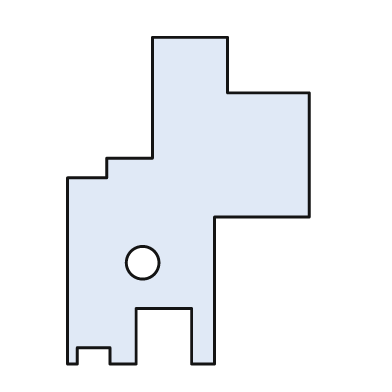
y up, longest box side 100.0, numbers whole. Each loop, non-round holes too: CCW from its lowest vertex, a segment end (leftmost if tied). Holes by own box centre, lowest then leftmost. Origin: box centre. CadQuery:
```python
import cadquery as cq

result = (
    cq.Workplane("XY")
    .moveTo(-37.0, -50.0)
    .lineTo(-34.0, -50.0)
    .lineTo(-34.0, -45.0)
    .lineTo(-24.0, -45.0)
    .lineTo(-24.0, -50.0)
    .lineTo(-16.0, -50.0)
    .lineTo(-16.0, -33.0)
    .lineTo(1.0, -33.0)
    .lineTo(1.0, -50.0)
    .lineTo(8.0, -50.0)
    .lineTo(8.0, -5.0)
    .lineTo(37.0, -5.0)
    .lineTo(37.0, 33.0)
    .lineTo(12.0, 33.0)
    .lineTo(12.0, 50.0)
    .lineTo(-11.0, 50.0)
    .lineTo(-11.0, 13.0)
    .lineTo(-25.0, 13.0)
    .lineTo(-25.0, 7.0)
    .lineTo(-37.0, 7.0)
    .close()
    .moveTo(-14.0, -19.0)
    .circle(5.0)
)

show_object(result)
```